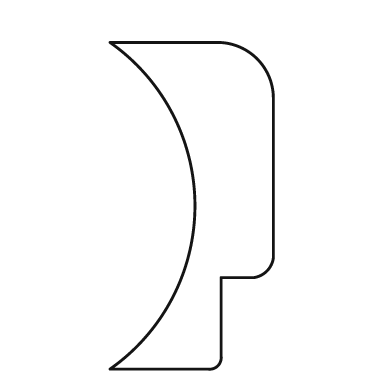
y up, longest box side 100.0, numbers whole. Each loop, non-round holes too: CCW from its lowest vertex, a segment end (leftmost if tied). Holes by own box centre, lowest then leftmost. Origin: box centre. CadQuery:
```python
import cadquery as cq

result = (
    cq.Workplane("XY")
    .moveTo(-25.0, -50.0)
    .lineTo(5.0, -50.0)
    .threePointArc((8.0, -49.0), (9.0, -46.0))
    .lineTo(9.0, -22.0)
    .lineTo(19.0, -22.0)
    .threePointArc((23.0, -20.0), (25.0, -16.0))
    .lineTo(25.0, 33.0)
    .threePointArc((20.0, 45.0), (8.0, 50.0))
    .lineTo(-25.0, 50.0)
    .threePointArc((1.0, 0.0), (-25.0, -50.0))
    .close()
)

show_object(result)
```